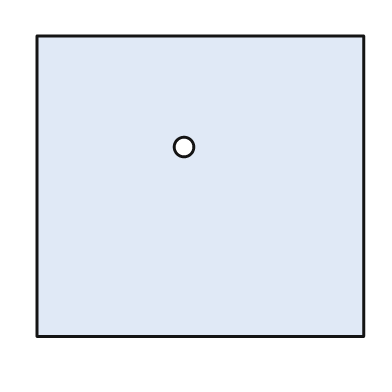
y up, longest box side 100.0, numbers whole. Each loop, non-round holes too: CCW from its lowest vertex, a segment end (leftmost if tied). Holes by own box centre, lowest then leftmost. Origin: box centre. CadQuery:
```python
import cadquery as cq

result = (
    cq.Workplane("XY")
    .moveTo(-50.0, -46.0)
    .lineTo(50.0, -46.0)
    .lineTo(50.0, 46.0)
    .lineTo(-50.0, 46.0)
    .close()
    .moveTo(-5.0, 12.0)
    .circle(3.0)
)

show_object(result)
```